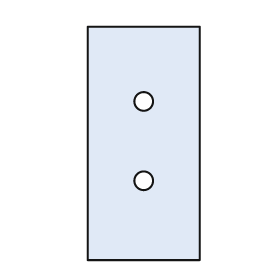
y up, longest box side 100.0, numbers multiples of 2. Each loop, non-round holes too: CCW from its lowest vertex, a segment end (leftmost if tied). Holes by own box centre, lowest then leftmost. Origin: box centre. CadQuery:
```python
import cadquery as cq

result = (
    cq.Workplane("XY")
    .moveTo(-24.0, -50.0)
    .lineTo(24.0, -50.0)
    .lineTo(24.0, 50.0)
    .lineTo(-24.0, 50.0)
    .close()
    .moveTo(0.0, -16.0)
    .circle(4.0)
    .moveTo(0.0, 18.0)
    .circle(4.0)
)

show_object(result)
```